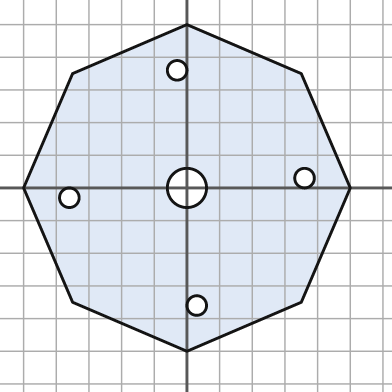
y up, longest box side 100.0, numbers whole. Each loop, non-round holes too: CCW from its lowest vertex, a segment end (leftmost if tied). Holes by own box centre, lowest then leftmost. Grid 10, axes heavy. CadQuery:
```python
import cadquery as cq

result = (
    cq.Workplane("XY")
    .moveTo(0.0, -50.0)
    .lineTo(35.0, -35.0)
    .lineTo(50.0, 0.0)
    .lineTo(35.0, 35.0)
    .lineTo(0.0, 50.0)
    .lineTo(-35.0, 35.0)
    .lineTo(-50.0, 0.0)
    .lineTo(-35.0, -35.0)
    .close()
    .moveTo(3.0, -36.0)
    .circle(3.0)
    .moveTo(-36.0, -3.0)
    .circle(3.0)
    .moveTo(0.0, 0.0)
    .circle(6.0)
    .moveTo(36.0, 3.0)
    .circle(3.0)
    .moveTo(-3.0, 36.0)
    .circle(3.0)
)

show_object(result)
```